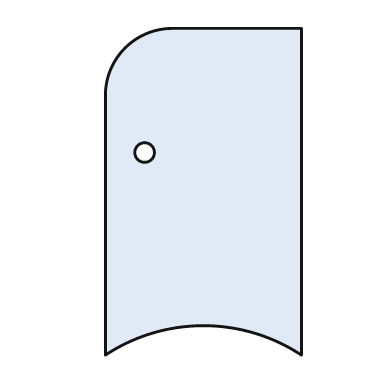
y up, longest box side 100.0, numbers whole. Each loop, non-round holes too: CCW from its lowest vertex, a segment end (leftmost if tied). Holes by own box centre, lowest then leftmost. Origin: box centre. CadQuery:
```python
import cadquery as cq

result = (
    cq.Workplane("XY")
    .moveTo(-30.0, -50.0)
    .threePointArc((0.0, -41.0), (30.0, -50.0))
    .lineTo(30.0, 50.0)
    .lineTo(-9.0, 50.0)
    .threePointArc((-24.0, 44.0), (-30.0, 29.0))
    .close()
    .moveTo(-18.0, 12.0)
    .circle(3.0)
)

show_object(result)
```